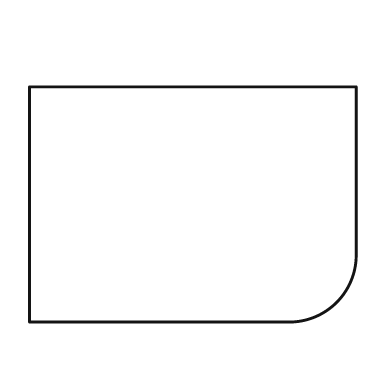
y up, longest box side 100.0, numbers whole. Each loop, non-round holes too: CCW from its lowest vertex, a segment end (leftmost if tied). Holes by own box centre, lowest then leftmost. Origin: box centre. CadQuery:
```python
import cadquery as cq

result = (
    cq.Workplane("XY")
    .moveTo(-50.0, -36.0)
    .lineTo(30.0, -36.0)
    .threePointArc((44.0, -30.0), (50.0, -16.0))
    .lineTo(50.0, 36.0)
    .lineTo(-50.0, 36.0)
    .close()
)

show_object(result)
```